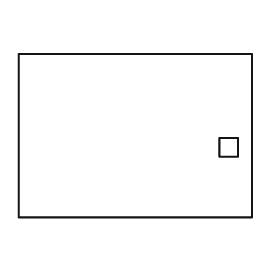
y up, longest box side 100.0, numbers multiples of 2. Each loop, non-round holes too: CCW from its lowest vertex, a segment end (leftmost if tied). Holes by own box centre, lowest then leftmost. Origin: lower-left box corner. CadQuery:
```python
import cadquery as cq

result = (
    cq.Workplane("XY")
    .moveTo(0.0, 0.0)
    .lineTo(100.0, 0.0)
    .lineTo(100.0, 70.0)
    .lineTo(0.0, 70.0)
    .close()
    .moveTo(86.0, 26.0)
    .lineTo(94.0, 26.0)
    .lineTo(94.0, 34.0)
    .lineTo(86.0, 34.0)
    .close()
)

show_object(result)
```